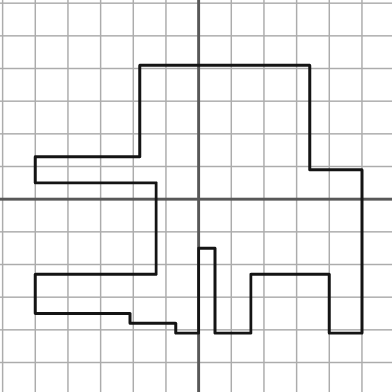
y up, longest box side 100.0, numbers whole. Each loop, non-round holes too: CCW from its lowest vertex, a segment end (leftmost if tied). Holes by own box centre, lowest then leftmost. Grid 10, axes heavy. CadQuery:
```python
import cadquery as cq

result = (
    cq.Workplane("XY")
    .moveTo(-7.0, -41.0)
    .lineTo(0.0, -41.0)
    .lineTo(0.0, -15.0)
    .lineTo(5.0, -15.0)
    .lineTo(5.0, -41.0)
    .lineTo(16.0, -41.0)
    .lineTo(16.0, -23.0)
    .lineTo(40.0, -23.0)
    .lineTo(40.0, -41.0)
    .lineTo(50.0, -41.0)
    .lineTo(50.0, 9.0)
    .lineTo(34.0, 9.0)
    .lineTo(34.0, 41.0)
    .lineTo(-18.0, 41.0)
    .lineTo(-18.0, 13.0)
    .lineTo(-50.0, 13.0)
    .lineTo(-50.0, 5.0)
    .lineTo(-13.0, 5.0)
    .lineTo(-13.0, -23.0)
    .lineTo(-50.0, -23.0)
    .lineTo(-50.0, -35.0)
    .lineTo(-21.0, -35.0)
    .lineTo(-21.0, -38.0)
    .lineTo(-7.0, -38.0)
    .close()
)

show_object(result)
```